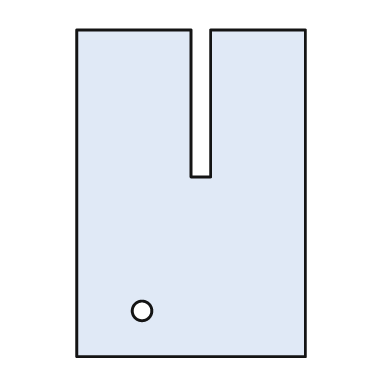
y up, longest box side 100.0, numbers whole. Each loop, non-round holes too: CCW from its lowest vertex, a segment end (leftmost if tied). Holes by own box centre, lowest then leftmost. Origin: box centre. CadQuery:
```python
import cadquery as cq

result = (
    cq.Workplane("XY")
    .moveTo(-35.0, -50.0)
    .lineTo(35.0, -50.0)
    .lineTo(35.0, 50.0)
    .lineTo(6.0, 50.0)
    .lineTo(6.0, 5.0)
    .lineTo(0.0, 5.0)
    .lineTo(0.0, 50.0)
    .lineTo(-35.0, 50.0)
    .close()
    .moveTo(-15.0, -36.0)
    .circle(3.0)
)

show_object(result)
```